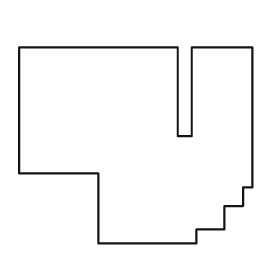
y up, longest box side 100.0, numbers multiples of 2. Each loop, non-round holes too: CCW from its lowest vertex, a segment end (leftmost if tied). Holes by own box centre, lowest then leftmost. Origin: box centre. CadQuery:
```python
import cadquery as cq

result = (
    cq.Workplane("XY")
    .moveTo(-16.0, -42.0)
    .lineTo(26.0, -42.0)
    .lineTo(26.0, -36.0)
    .lineTo(38.0, -36.0)
    .lineTo(38.0, -26.0)
    .lineTo(46.0, -26.0)
    .lineTo(46.0, -18.0)
    .lineTo(50.0, -18.0)
    .lineTo(50.0, 42.0)
    .lineTo(24.0, 42.0)
    .lineTo(24.0, 4.0)
    .lineTo(18.0, 4.0)
    .lineTo(18.0, 42.0)
    .lineTo(-50.0, 42.0)
    .lineTo(-50.0, -12.0)
    .lineTo(-16.0, -12.0)
    .close()
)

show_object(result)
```